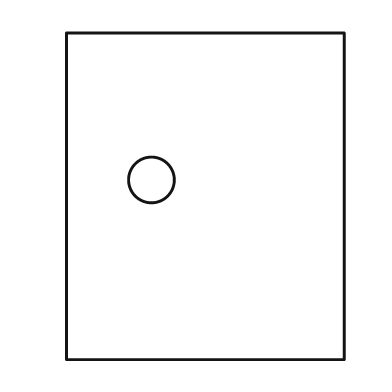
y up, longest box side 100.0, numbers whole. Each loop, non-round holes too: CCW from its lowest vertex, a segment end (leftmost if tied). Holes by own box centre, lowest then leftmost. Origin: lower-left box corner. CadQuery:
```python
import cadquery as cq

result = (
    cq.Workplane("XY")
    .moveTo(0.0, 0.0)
    .lineTo(85.0, 0.0)
    .lineTo(85.0, 100.0)
    .lineTo(0.0, 100.0)
    .close()
    .moveTo(26.0, 55.0)
    .circle(7.0)
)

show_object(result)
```